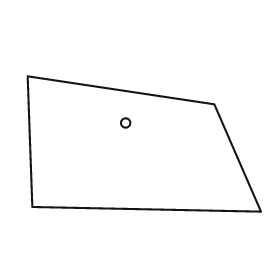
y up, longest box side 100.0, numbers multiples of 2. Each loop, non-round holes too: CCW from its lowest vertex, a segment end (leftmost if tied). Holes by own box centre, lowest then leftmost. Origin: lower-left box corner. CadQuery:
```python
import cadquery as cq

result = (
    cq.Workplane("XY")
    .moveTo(100.0, 0.0)
    .lineTo(80.0, 46.0)
    .lineTo(0.0, 58.0)
    .lineTo(2.0, 2.0)
    .close()
    .moveTo(42.0, 38.0)
    .circle(2.0)
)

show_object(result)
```